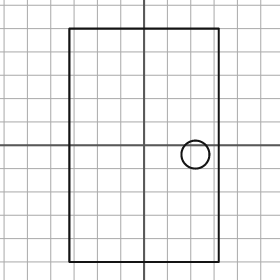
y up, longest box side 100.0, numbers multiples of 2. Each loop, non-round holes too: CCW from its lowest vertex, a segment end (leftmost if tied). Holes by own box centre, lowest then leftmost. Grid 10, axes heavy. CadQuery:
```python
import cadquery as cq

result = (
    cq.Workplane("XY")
    .moveTo(-32.0, -50.0)
    .lineTo(32.0, -50.0)
    .lineTo(32.0, 50.0)
    .lineTo(-32.0, 50.0)
    .close()
    .moveTo(22.0, -4.0)
    .circle(6.0)
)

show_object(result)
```